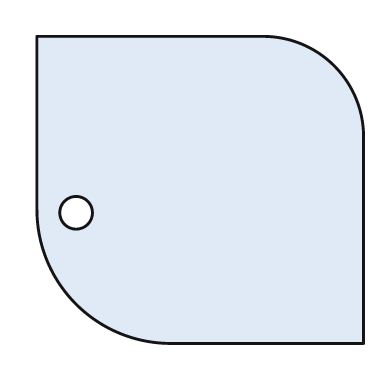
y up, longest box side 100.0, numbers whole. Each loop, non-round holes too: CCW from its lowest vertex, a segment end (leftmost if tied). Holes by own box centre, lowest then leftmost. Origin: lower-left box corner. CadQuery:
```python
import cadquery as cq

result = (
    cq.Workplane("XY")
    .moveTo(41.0, 0.0)
    .lineTo(100.0, 0.0)
    .lineTo(100.0, 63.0)
    .threePointArc((91.0, 85.0), (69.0, 94.0))
    .lineTo(0.0, 94.0)
    .lineTo(0.0, 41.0)
    .threePointArc((12.0, 12.0), (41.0, 0.0))
    .close()
    .moveTo(12.0, 40.0)
    .circle(5.0)
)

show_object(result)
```